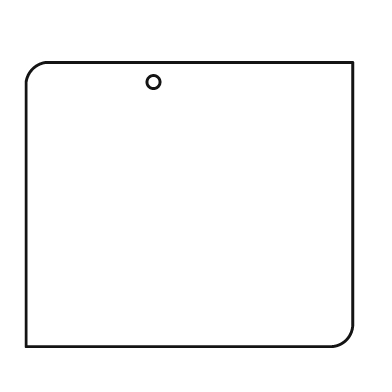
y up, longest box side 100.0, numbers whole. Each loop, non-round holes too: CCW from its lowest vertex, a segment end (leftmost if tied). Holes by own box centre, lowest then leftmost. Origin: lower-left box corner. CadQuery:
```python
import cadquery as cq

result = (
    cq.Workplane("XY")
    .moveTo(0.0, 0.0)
    .lineTo(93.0, 0.0)
    .threePointArc((98.0, 2.0), (100.0, 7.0))
    .lineTo(100.0, 87.0)
    .lineTo(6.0, 87.0)
    .threePointArc((2.0, 85.0), (0.0, 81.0))
    .close()
    .moveTo(39.0, 81.0)
    .circle(2.0)
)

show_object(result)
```